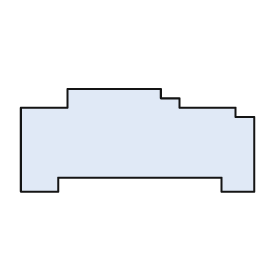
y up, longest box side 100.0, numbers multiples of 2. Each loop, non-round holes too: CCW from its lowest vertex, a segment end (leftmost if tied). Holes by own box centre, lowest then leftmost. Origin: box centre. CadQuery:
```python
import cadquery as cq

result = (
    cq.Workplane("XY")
    .moveTo(-50.0, -22.0)
    .lineTo(-34.0, -22.0)
    .lineTo(-34.0, -16.0)
    .lineTo(36.0, -16.0)
    .lineTo(36.0, -22.0)
    .lineTo(50.0, -22.0)
    .lineTo(50.0, 10.0)
    .lineTo(42.0, 10.0)
    .lineTo(42.0, 14.0)
    .lineTo(18.0, 14.0)
    .lineTo(18.0, 18.0)
    .lineTo(10.0, 18.0)
    .lineTo(10.0, 22.0)
    .lineTo(-30.0, 22.0)
    .lineTo(-30.0, 14.0)
    .lineTo(-50.0, 14.0)
    .close()
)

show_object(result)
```